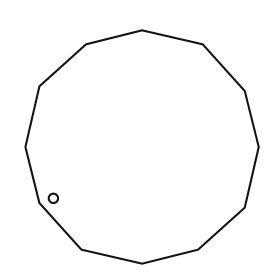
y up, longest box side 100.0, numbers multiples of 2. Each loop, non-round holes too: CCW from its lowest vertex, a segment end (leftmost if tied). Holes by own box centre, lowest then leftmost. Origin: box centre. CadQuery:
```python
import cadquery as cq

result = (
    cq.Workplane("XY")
    .moveTo(0.0, -50.0)
    .lineTo(24.0, -44.0)
    .lineTo(44.0, -26.0)
    .lineTo(50.0, 0.0)
    .lineTo(44.0, 24.0)
    .lineTo(26.0, 44.0)
    .lineTo(0.0, 50.0)
    .lineTo(-24.0, 44.0)
    .lineTo(-44.0, 26.0)
    .lineTo(-50.0, 0.0)
    .lineTo(-44.0, -24.0)
    .lineTo(-26.0, -44.0)
    .close()
    .moveTo(-38.0, -22.0)
    .circle(2.0)
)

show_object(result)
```